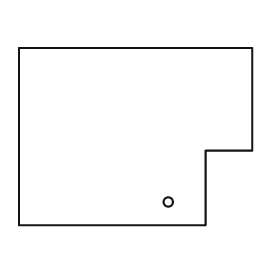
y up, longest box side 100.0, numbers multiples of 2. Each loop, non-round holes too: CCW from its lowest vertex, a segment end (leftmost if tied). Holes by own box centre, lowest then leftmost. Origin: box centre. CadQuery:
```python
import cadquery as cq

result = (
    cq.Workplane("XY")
    .moveTo(-50.0, -38.0)
    .lineTo(30.0, -38.0)
    .lineTo(30.0, -6.0)
    .lineTo(50.0, -6.0)
    .lineTo(50.0, 38.0)
    .lineTo(-50.0, 38.0)
    .close()
    .moveTo(14.0, -28.0)
    .circle(2.0)
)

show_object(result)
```